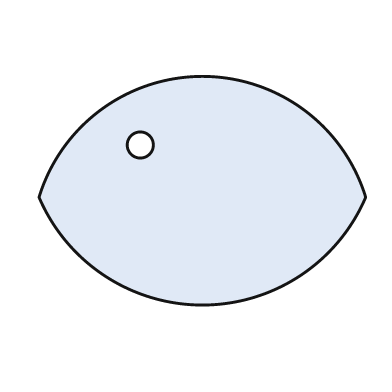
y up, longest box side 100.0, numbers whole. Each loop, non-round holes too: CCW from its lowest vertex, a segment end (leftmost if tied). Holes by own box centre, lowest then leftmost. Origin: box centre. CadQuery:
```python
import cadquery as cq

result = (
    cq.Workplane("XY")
    .moveTo(-50.0, -2.0)
    .threePointArc((0.0, -35.0), (50.0, -2.0))
    .threePointArc((0.0, 35.0), (-50.0, -2.0))
    .close()
    .moveTo(-19.0, 14.0)
    .circle(4.0)
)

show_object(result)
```